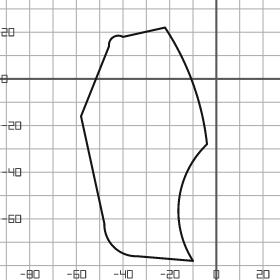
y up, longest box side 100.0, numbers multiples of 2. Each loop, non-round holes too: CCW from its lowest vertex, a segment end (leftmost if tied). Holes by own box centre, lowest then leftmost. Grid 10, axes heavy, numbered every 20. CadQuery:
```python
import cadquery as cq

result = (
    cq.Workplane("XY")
    .moveTo(-10.0, -78.0)
    .threePointArc((-16.0, -52.0), (-4.0, -28.0))
    .threePointArc((-10.0, -2.0), (-22.0, 22.0))
    .lineTo(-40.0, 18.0)
    .threePointArc((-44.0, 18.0), (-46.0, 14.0))
    .lineTo(-58.0, -16.0)
    .lineTo(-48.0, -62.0)
    .threePointArc((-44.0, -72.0), (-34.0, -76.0))
    .close()
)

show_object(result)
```